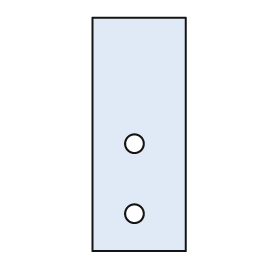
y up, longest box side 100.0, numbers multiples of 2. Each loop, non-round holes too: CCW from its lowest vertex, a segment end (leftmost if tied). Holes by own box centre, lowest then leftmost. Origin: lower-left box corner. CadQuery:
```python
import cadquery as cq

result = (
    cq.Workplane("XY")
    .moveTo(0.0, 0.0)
    .lineTo(40.0, 0.0)
    .lineTo(40.0, 100.0)
    .lineTo(0.0, 100.0)
    .close()
    .moveTo(18.0, 16.0)
    .circle(4.0)
    .moveTo(18.0, 46.0)
    .circle(4.0)
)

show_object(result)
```